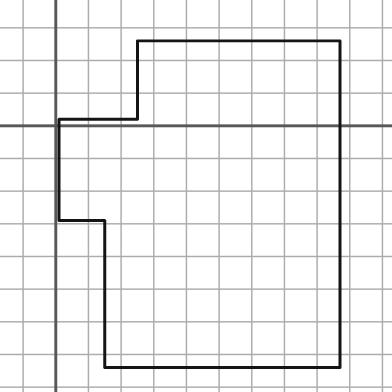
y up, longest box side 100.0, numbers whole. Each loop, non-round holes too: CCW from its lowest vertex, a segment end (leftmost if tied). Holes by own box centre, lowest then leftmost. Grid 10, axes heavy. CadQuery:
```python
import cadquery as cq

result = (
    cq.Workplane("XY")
    .moveTo(15.0, -74.0)
    .lineTo(87.0, -74.0)
    .lineTo(87.0, 26.0)
    .lineTo(25.0, 26.0)
    .lineTo(25.0, 2.0)
    .lineTo(1.0, 2.0)
    .lineTo(1.0, -29.0)
    .lineTo(15.0, -29.0)
    .close()
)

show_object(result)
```